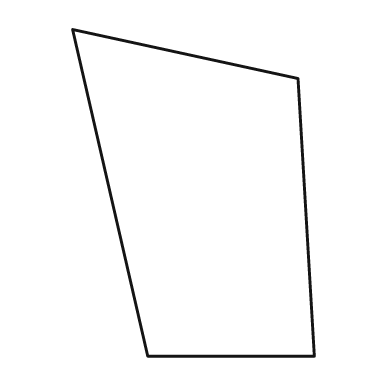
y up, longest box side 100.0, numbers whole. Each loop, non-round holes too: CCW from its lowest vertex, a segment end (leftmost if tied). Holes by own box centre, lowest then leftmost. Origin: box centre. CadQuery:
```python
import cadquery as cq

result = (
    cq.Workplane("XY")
    .moveTo(-14.0, -50.0)
    .lineTo(37.0, -50.0)
    .lineTo(32.0, 35.0)
    .lineTo(-37.0, 50.0)
    .close()
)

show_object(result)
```